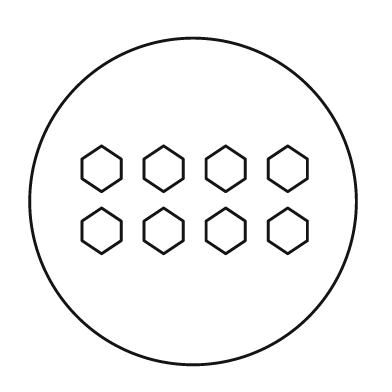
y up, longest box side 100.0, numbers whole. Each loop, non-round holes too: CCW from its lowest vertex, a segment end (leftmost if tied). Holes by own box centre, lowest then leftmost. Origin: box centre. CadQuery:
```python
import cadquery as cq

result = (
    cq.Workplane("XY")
    .moveTo(0.0, 0.0)
    .circle(50.0)
    .moveTo(-28.0, -16.0)
    .lineTo(-22.0, -12.0)
    .lineTo(-22.0, -6.0)
    .lineTo(-28.0, -2.0)
    .lineTo(-34.0, -6.0)
    .lineTo(-34.0, -12.0)
    .close()
    .moveTo(-9.0, -16.0)
    .lineTo(-3.0, -12.0)
    .lineTo(-3.0, -6.0)
    .lineTo(-9.0, -2.0)
    .lineTo(-15.0, -6.0)
    .lineTo(-15.0, -12.0)
    .close()
    .moveTo(10.0, -16.0)
    .lineTo(16.0, -12.0)
    .lineTo(16.0, -6.0)
    .lineTo(10.0, -2.0)
    .lineTo(4.0, -6.0)
    .lineTo(4.0, -12.0)
    .close()
    .moveTo(29.0, -16.0)
    .lineTo(35.0, -12.0)
    .lineTo(35.0, -6.0)
    .lineTo(29.0, -2.0)
    .lineTo(23.0, -6.0)
    .lineTo(23.0, -12.0)
    .close()
    .moveTo(-28.0, 3.0)
    .lineTo(-22.0, 7.0)
    .lineTo(-22.0, 13.0)
    .lineTo(-28.0, 17.0)
    .lineTo(-34.0, 13.0)
    .lineTo(-34.0, 7.0)
    .close()
    .moveTo(-9.0, 3.0)
    .lineTo(-3.0, 7.0)
    .lineTo(-3.0, 13.0)
    .lineTo(-9.0, 17.0)
    .lineTo(-15.0, 13.0)
    .lineTo(-15.0, 7.0)
    .close()
    .moveTo(10.0, 3.0)
    .lineTo(16.0, 7.0)
    .lineTo(16.0, 13.0)
    .lineTo(10.0, 17.0)
    .lineTo(4.0, 13.0)
    .lineTo(4.0, 7.0)
    .close()
    .moveTo(29.0, 3.0)
    .lineTo(35.0, 7.0)
    .lineTo(35.0, 13.0)
    .lineTo(29.0, 17.0)
    .lineTo(23.0, 13.0)
    .lineTo(23.0, 7.0)
    .close()
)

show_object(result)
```